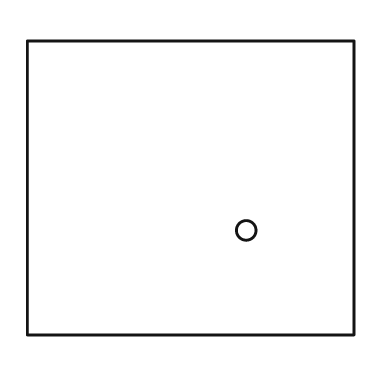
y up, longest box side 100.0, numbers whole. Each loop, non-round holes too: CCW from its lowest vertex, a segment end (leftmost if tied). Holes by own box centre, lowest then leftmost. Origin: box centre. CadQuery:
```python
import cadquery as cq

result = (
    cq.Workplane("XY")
    .moveTo(-50.0, -45.0)
    .lineTo(50.0, -45.0)
    .lineTo(50.0, 45.0)
    .lineTo(-50.0, 45.0)
    .close()
    .moveTo(17.0, -13.0)
    .circle(3.0)
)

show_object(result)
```